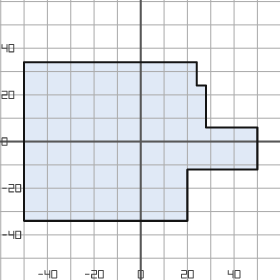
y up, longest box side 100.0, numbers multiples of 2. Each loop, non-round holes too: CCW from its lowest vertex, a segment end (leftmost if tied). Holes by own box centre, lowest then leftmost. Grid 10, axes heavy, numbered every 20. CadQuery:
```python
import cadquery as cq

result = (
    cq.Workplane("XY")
    .moveTo(-50.0, -34.0)
    .lineTo(20.0, -34.0)
    .lineTo(20.0, -12.0)
    .lineTo(50.0, -12.0)
    .lineTo(50.0, 6.0)
    .lineTo(28.0, 6.0)
    .lineTo(28.0, 24.0)
    .lineTo(24.0, 24.0)
    .lineTo(24.0, 34.0)
    .lineTo(-50.0, 34.0)
    .close()
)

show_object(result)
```